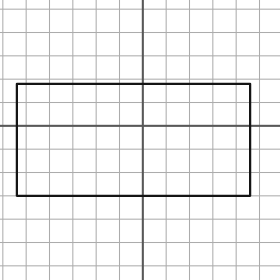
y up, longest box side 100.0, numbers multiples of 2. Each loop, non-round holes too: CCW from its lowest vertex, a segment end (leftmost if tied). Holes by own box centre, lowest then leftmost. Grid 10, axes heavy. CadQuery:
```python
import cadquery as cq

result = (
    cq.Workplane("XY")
    .moveTo(-54.0, -30.0)
    .lineTo(46.0, -30.0)
    .lineTo(46.0, 18.0)
    .lineTo(-54.0, 18.0)
    .close()
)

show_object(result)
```